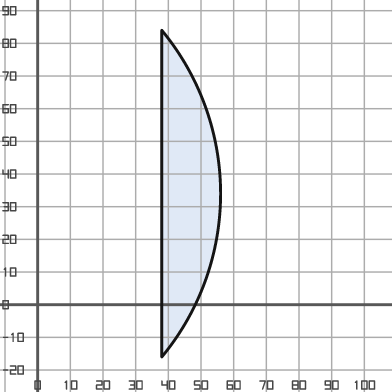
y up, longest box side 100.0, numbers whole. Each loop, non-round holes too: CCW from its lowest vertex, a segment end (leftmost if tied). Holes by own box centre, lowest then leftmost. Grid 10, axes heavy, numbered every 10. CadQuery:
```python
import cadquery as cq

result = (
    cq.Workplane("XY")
    .moveTo(38.0, -16.0)
    .threePointArc((56.0, 34.0), (38.0, 84.0))
    .close()
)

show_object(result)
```